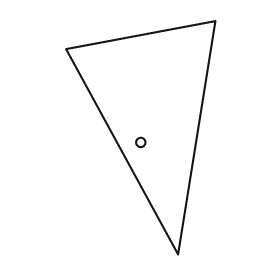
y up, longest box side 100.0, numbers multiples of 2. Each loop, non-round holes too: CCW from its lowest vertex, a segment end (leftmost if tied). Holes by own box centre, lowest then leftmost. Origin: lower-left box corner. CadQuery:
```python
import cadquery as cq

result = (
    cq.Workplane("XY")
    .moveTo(48.0, 0.0)
    .lineTo(64.0, 100.0)
    .lineTo(0.0, 88.0)
    .close()
    .moveTo(32.0, 48.0)
    .circle(2.0)
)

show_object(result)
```